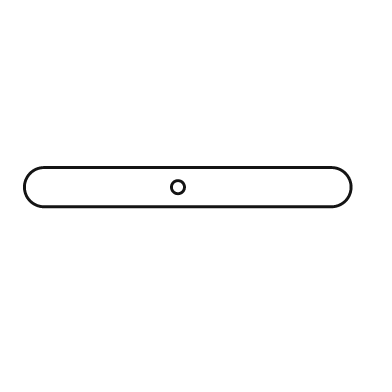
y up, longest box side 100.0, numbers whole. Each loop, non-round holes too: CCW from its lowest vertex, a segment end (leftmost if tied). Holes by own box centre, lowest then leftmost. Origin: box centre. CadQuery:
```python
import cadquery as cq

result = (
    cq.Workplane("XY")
    .moveTo(-44.0, -6.0)
    .lineTo(44.0, -6.0)
    .threePointArc((50.0, 0.0), (44.0, 6.0))
    .lineTo(-44.0, 6.0)
    .threePointArc((-50.0, 0.0), (-44.0, -6.0))
    .close()
    .moveTo(-3.0, 0.0)
    .circle(2.0)
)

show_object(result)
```